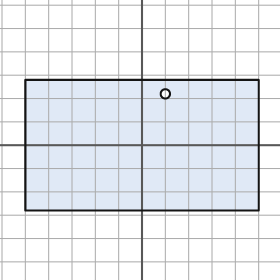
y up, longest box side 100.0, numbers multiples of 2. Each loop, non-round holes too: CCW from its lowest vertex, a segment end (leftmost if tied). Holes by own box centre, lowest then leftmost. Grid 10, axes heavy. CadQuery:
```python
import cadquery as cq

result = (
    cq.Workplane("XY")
    .moveTo(-50.0, -28.0)
    .lineTo(50.0, -28.0)
    .lineTo(50.0, 28.0)
    .lineTo(-50.0, 28.0)
    .close()
    .moveTo(10.0, 22.0)
    .circle(2.0)
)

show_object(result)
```